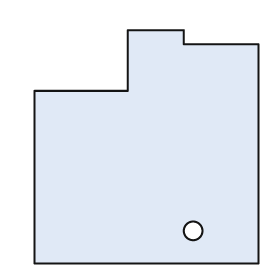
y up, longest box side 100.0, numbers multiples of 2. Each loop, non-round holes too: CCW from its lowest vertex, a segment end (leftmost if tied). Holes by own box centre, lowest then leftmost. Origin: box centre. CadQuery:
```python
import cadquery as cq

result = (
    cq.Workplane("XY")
    .moveTo(-48.0, -50.0)
    .lineTo(48.0, -50.0)
    .lineTo(48.0, 44.0)
    .lineTo(16.0, 44.0)
    .lineTo(16.0, 50.0)
    .lineTo(-8.0, 50.0)
    .lineTo(-8.0, 24.0)
    .lineTo(-48.0, 24.0)
    .close()
    .moveTo(20.0, -36.0)
    .circle(4.0)
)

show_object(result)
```